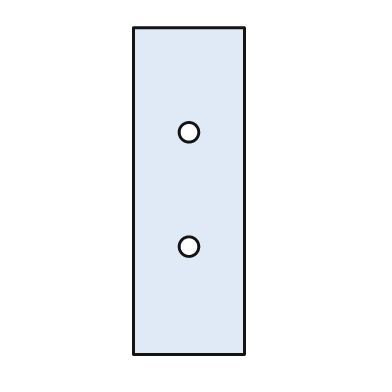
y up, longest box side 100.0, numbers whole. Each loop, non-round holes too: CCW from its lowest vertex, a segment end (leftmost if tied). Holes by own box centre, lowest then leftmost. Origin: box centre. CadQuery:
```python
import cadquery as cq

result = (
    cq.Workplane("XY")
    .moveTo(-17.0, -50.0)
    .lineTo(17.0, -50.0)
    .lineTo(17.0, 50.0)
    .lineTo(-17.0, 50.0)
    .close()
    .moveTo(0.0, -17.0)
    .circle(3.0)
    .moveTo(0.0, 18.0)
    .circle(3.0)
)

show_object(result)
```